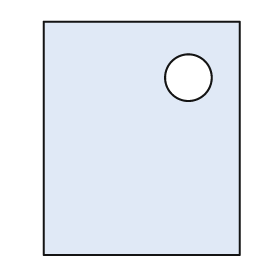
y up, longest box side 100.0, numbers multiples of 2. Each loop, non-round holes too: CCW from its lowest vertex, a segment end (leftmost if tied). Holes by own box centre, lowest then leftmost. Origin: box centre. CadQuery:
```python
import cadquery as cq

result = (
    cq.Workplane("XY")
    .moveTo(-42.0, -50.0)
    .lineTo(42.0, -50.0)
    .lineTo(42.0, 50.0)
    .lineTo(-42.0, 50.0)
    .close()
    .moveTo(20.0, 26.0)
    .circle(10.0)
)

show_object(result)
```